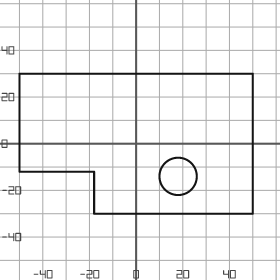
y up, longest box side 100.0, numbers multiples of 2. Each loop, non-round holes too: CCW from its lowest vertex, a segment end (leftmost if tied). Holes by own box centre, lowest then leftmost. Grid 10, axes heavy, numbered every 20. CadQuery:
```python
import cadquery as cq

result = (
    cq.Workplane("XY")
    .moveTo(-18.0, -30.0)
    .lineTo(50.0, -30.0)
    .lineTo(50.0, 30.0)
    .lineTo(-50.0, 30.0)
    .lineTo(-50.0, -12.0)
    .lineTo(-18.0, -12.0)
    .close()
    .moveTo(18.0, -14.0)
    .circle(8.0)
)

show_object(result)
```